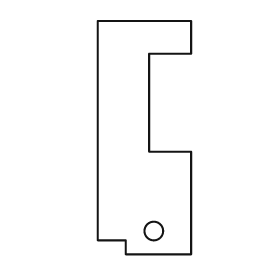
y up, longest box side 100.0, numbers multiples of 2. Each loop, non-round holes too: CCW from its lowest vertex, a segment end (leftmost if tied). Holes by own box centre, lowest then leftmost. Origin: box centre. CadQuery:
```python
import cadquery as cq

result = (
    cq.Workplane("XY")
    .moveTo(-8.0, -50.0)
    .lineTo(20.0, -50.0)
    .lineTo(20.0, -6.0)
    .lineTo(2.0, -6.0)
    .lineTo(2.0, 36.0)
    .lineTo(20.0, 36.0)
    .lineTo(20.0, 50.0)
    .lineTo(-20.0, 50.0)
    .lineTo(-20.0, -44.0)
    .lineTo(-8.0, -44.0)
    .close()
    .moveTo(4.0, -40.0)
    .circle(4.0)
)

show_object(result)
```